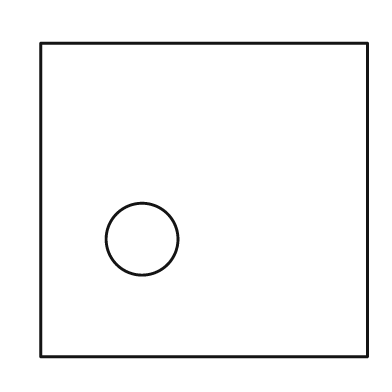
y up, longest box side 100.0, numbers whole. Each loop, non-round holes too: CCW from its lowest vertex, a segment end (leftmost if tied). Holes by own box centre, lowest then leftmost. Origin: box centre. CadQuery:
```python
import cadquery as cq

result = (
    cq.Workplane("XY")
    .moveTo(-50.0, -48.0)
    .lineTo(50.0, -48.0)
    .lineTo(50.0, 48.0)
    .lineTo(-50.0, 48.0)
    .close()
    .moveTo(-19.0, -12.0)
    .circle(11.0)
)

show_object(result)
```